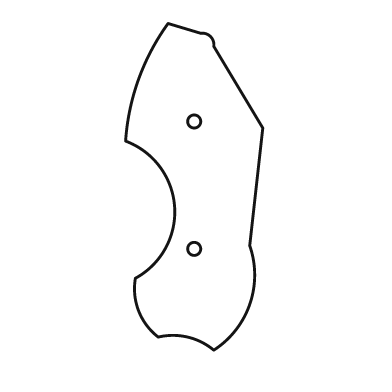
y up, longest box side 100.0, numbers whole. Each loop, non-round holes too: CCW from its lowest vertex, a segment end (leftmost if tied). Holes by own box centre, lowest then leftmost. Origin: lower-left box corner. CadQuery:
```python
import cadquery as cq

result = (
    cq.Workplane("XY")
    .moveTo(27.0, 0.0)
    .threePointArc((38.0, 14.0), (38.0, 32.0))
    .lineTo(42.0, 68.0)
    .lineTo(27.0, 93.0)
    .threePointArc((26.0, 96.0), (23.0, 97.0))
    .lineTo(13.0, 100.0)
    .threePointArc((4.0, 83.0), (0.0, 64.0))
    .threePointArc((15.0, 44.0), (3.0, 22.0))
    .threePointArc((4.0, 12.0), (10.0, 4.0))
    .threePointArc((19.0, 4.0), (27.0, 0.0))
    .close()
    .moveTo(21.0, 31.0)
    .circle(2.0)
    .moveTo(21.0, 70.0)
    .circle(2.0)
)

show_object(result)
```